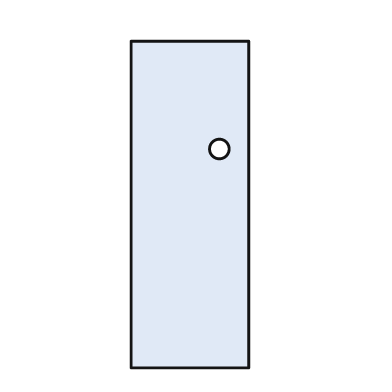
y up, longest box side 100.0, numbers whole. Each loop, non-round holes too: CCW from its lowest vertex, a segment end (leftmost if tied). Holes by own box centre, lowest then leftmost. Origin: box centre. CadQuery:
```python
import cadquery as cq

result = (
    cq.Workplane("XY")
    .moveTo(-18.0, -50.0)
    .lineTo(18.0, -50.0)
    .lineTo(18.0, 50.0)
    .lineTo(-18.0, 50.0)
    .close()
    .moveTo(9.0, 17.0)
    .circle(3.0)
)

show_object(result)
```